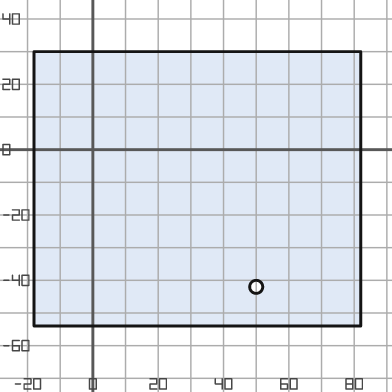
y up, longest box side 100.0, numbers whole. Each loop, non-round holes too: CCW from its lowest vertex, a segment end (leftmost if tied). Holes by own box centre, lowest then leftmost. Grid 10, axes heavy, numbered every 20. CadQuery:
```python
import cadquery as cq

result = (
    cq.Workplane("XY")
    .moveTo(-18.0, -54.0)
    .lineTo(82.0, -54.0)
    .lineTo(82.0, 30.0)
    .lineTo(-18.0, 30.0)
    .close()
    .moveTo(50.0, -42.0)
    .circle(2.0)
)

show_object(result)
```